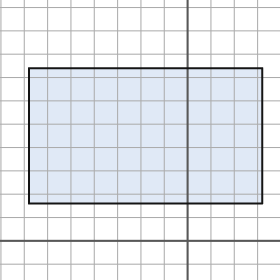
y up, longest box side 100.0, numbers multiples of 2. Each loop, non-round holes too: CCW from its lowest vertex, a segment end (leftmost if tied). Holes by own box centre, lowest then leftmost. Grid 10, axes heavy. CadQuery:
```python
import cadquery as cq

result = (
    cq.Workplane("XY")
    .moveTo(-68.0, 16.0)
    .lineTo(32.0, 16.0)
    .lineTo(32.0, 74.0)
    .lineTo(-68.0, 74.0)
    .close()
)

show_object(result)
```